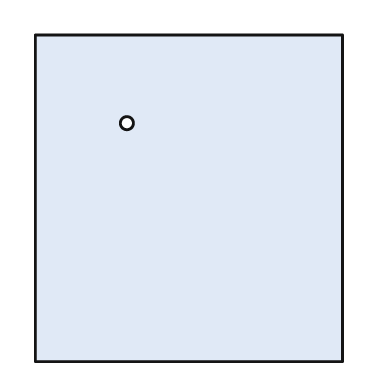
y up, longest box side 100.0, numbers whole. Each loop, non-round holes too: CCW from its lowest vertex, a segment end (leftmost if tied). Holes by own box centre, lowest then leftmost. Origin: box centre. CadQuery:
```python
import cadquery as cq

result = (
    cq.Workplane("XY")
    .moveTo(-47.0, -50.0)
    .lineTo(47.0, -50.0)
    .lineTo(47.0, 50.0)
    .lineTo(-47.0, 50.0)
    .close()
    .moveTo(-19.0, 23.0)
    .circle(2.0)
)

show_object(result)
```